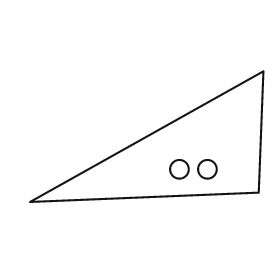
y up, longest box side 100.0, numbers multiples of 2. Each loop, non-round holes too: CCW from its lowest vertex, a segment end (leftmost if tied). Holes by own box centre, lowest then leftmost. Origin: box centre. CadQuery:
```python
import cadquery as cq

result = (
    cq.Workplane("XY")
    .moveTo(-50.0, -28.0)
    .lineTo(48.0, -24.0)
    .lineTo(50.0, 28.0)
    .close()
    .moveTo(14.0, -14.0)
    .circle(4.0)
    .moveTo(26.0, -14.0)
    .circle(4.0)
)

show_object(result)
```